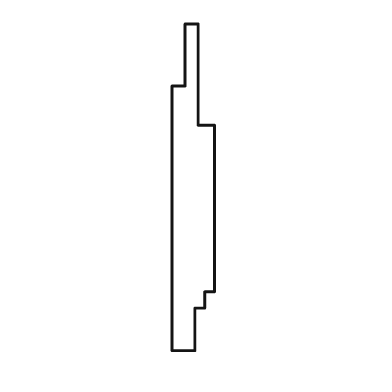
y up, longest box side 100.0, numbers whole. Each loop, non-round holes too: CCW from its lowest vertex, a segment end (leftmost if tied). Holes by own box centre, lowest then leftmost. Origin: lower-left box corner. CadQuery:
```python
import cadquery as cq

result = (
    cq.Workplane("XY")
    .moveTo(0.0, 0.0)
    .lineTo(7.0, 0.0)
    .lineTo(7.0, 13.0)
    .lineTo(10.0, 13.0)
    .lineTo(10.0, 18.0)
    .lineTo(13.0, 18.0)
    .lineTo(13.0, 69.0)
    .lineTo(8.0, 69.0)
    .lineTo(8.0, 100.0)
    .lineTo(4.0, 100.0)
    .lineTo(4.0, 81.0)
    .lineTo(0.0, 81.0)
    .close()
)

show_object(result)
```